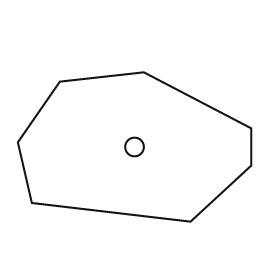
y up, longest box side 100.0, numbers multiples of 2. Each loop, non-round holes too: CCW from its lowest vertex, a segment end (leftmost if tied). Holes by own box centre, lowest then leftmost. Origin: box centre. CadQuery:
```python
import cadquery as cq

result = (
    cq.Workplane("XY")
    .moveTo(24.0, -32.0)
    .lineTo(50.0, -8.0)
    .lineTo(50.0, 8.0)
    .lineTo(4.0, 32.0)
    .lineTo(-32.0, 28.0)
    .lineTo(-50.0, 2.0)
    .lineTo(-44.0, -24.0)
    .close()
    .moveTo(0.0, 0.0)
    .circle(4.0)
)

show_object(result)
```